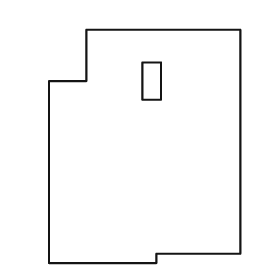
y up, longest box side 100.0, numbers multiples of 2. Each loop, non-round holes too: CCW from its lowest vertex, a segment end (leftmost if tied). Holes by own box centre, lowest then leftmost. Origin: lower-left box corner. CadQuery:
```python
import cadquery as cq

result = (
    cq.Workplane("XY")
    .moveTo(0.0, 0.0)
    .lineTo(46.0, 0.0)
    .lineTo(46.0, 4.0)
    .lineTo(82.0, 4.0)
    .lineTo(82.0, 100.0)
    .lineTo(16.0, 100.0)
    .lineTo(16.0, 78.0)
    .lineTo(0.0, 78.0)
    .close()
    .moveTo(40.0, 70.0)
    .lineTo(48.0, 70.0)
    .lineTo(48.0, 86.0)
    .lineTo(40.0, 86.0)
    .close()
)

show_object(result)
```